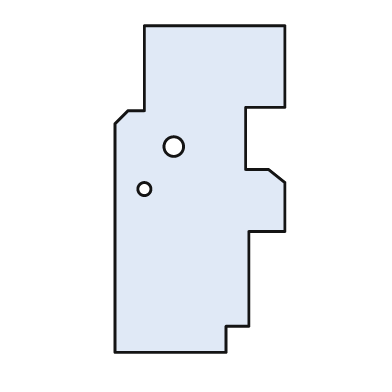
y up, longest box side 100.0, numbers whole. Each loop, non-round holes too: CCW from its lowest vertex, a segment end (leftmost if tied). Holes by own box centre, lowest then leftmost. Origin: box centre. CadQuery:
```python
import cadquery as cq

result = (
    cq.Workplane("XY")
    .moveTo(-26.0, -50.0)
    .lineTo(8.0, -50.0)
    .lineTo(8.0, -42.0)
    .lineTo(15.0, -42.0)
    .lineTo(15.0, -13.0)
    .lineTo(26.0, -13.0)
    .lineTo(26.0, 2.0)
    .lineTo(21.0, 6.0)
    .lineTo(14.0, 6.0)
    .lineTo(14.0, 25.0)
    .lineTo(26.0, 25.0)
    .lineTo(26.0, 50.0)
    .lineTo(-17.0, 50.0)
    .lineTo(-17.0, 24.0)
    .lineTo(-22.0, 24.0)
    .lineTo(-26.0, 20.0)
    .close()
    .moveTo(-17.0, 0.0)
    .circle(2.0)
    .moveTo(-8.0, 13.0)
    .circle(3.0)
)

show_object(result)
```